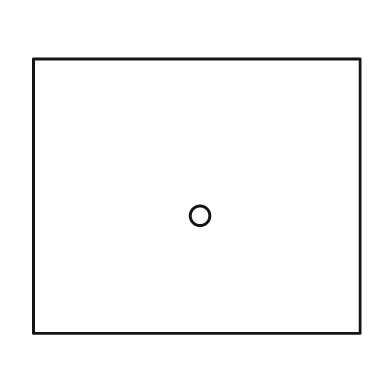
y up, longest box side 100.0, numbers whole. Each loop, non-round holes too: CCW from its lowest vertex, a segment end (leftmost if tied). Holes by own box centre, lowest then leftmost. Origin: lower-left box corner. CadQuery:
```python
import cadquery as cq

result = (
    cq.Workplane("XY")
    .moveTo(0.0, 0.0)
    .lineTo(100.0, 0.0)
    .lineTo(100.0, 84.0)
    .lineTo(0.0, 84.0)
    .close()
    .moveTo(51.0, 36.0)
    .circle(3.0)
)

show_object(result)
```